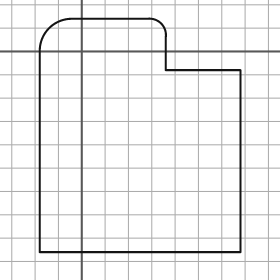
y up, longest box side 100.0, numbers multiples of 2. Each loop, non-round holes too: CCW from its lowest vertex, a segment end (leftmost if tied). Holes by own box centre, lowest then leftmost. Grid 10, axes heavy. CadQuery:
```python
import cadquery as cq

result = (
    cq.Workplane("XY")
    .moveTo(-18.0, -86.0)
    .lineTo(68.0, -86.0)
    .lineTo(68.0, -8.0)
    .lineTo(36.0, -8.0)
    .lineTo(36.0, 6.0)
    .threePointArc((34.0, 12.0), (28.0, 14.0))
    .lineTo(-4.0, 14.0)
    .threePointArc((-14.0, 10.0), (-18.0, 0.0))
    .close()
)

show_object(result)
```